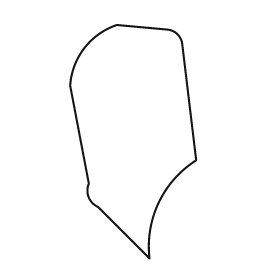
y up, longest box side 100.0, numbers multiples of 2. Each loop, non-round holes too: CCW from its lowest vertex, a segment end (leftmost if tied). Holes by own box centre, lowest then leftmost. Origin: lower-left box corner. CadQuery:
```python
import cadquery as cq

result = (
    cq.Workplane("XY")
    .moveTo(34.0, 0.0)
    .threePointArc((38.0, 24.0), (54.0, 42.0))
    .lineTo(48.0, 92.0)
    .threePointArc((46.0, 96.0), (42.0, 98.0))
    .lineTo(20.0, 100.0)
    .threePointArc((6.0, 90.0), (0.0, 74.0))
    .lineTo(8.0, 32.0)
    .threePointArc((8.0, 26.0), (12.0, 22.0))
    .close()
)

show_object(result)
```